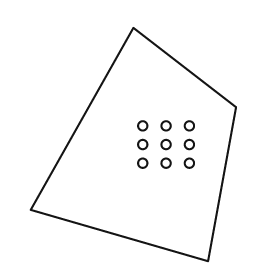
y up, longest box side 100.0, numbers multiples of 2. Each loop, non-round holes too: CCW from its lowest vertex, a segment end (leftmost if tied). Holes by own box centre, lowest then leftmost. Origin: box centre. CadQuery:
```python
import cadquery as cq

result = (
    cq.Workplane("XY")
    .moveTo(32.0, -50.0)
    .lineTo(44.0, 16.0)
    .lineTo(0.0, 50.0)
    .lineTo(-44.0, -28.0)
    .close()
    .moveTo(4.0, -8.0)
    .circle(2.0)
    .moveTo(14.0, -8.0)
    .circle(2.0)
    .moveTo(24.0, -8.0)
    .circle(2.0)
    .moveTo(4.0, 0.0)
    .circle(2.0)
    .moveTo(14.0, 0.0)
    .circle(2.0)
    .moveTo(24.0, 0.0)
    .circle(2.0)
    .moveTo(4.0, 8.0)
    .circle(2.0)
    .moveTo(14.0, 8.0)
    .circle(2.0)
    .moveTo(24.0, 8.0)
    .circle(2.0)
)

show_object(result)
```